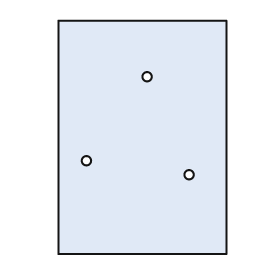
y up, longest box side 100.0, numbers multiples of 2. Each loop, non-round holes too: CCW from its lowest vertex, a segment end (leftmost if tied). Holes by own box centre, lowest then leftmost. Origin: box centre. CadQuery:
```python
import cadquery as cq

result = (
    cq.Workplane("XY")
    .moveTo(-36.0, -50.0)
    .lineTo(36.0, -50.0)
    .lineTo(36.0, 50.0)
    .lineTo(-36.0, 50.0)
    .close()
    .moveTo(20.0, -16.0)
    .circle(2.0)
    .moveTo(-24.0, -10.0)
    .circle(2.0)
    .moveTo(2.0, 26.0)
    .circle(2.0)
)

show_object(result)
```